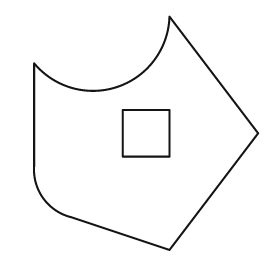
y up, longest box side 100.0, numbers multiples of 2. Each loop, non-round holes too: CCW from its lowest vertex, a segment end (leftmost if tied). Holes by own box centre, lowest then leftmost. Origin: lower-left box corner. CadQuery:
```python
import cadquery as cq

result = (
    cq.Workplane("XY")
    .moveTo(58.0, 0.0)
    .lineTo(96.0, 50.0)
    .lineTo(58.0, 100.0)
    .threePointArc((36.0, 70.0), (0.0, 80.0))
    .lineTo(0.0, 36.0)
    .threePointArc((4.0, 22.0), (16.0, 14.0))
    .close()
    .moveTo(38.0, 40.0)
    .lineTo(58.0, 40.0)
    .lineTo(58.0, 60.0)
    .lineTo(38.0, 60.0)
    .close()
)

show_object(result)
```